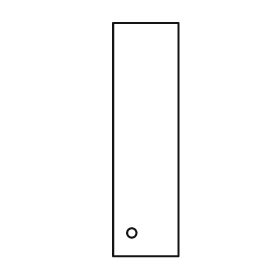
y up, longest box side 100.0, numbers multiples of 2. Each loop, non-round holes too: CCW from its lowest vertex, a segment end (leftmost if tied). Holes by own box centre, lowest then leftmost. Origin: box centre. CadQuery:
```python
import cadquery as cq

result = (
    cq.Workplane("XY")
    .moveTo(-14.0, -50.0)
    .lineTo(14.0, -50.0)
    .lineTo(14.0, 50.0)
    .lineTo(-14.0, 50.0)
    .close()
    .moveTo(-6.0, -40.0)
    .circle(2.0)
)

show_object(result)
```